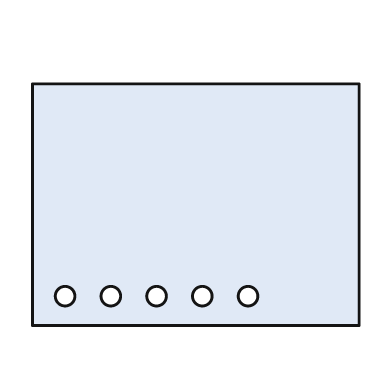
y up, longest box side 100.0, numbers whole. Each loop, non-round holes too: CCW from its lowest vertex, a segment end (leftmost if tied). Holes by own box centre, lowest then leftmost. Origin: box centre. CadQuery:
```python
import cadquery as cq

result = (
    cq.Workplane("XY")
    .moveTo(-50.0, -37.0)
    .lineTo(50.0, -37.0)
    .lineTo(50.0, 37.0)
    .lineTo(-50.0, 37.0)
    .close()
    .moveTo(-40.0, -28.0)
    .circle(3.0)
    .moveTo(-26.0, -28.0)
    .circle(3.0)
    .moveTo(-12.0, -28.0)
    .circle(3.0)
    .moveTo(2.0, -28.0)
    .circle(3.0)
    .moveTo(16.0, -28.0)
    .circle(3.0)
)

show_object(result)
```